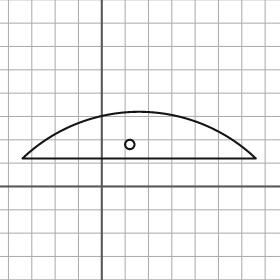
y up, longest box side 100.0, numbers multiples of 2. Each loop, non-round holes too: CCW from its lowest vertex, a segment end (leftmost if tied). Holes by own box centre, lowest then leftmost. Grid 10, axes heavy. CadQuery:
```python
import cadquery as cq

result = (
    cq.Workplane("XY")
    .moveTo(-34.0, 12.0)
    .lineTo(66.0, 12.0)
    .threePointArc((16.0, 32.0), (-34.0, 12.0))
    .close()
    .moveTo(12.0, 18.0)
    .circle(2.0)
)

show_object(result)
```